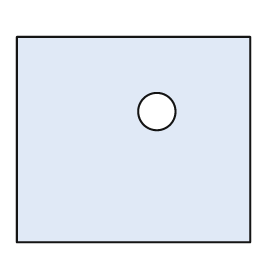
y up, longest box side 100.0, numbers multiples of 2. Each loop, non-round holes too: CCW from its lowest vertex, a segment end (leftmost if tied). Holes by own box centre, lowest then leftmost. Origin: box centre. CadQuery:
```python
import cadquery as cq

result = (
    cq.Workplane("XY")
    .moveTo(-50.0, -44.0)
    .lineTo(50.0, -44.0)
    .lineTo(50.0, 44.0)
    .lineTo(-50.0, 44.0)
    .close()
    .moveTo(10.0, 12.0)
    .circle(8.0)
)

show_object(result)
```